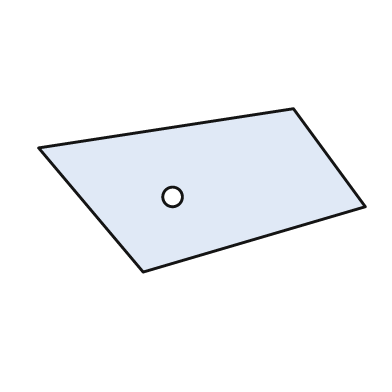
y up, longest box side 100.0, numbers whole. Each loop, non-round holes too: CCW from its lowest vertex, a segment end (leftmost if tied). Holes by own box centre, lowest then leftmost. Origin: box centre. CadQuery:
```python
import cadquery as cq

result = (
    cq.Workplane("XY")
    .moveTo(-18.0, -25.0)
    .lineTo(50.0, -5.0)
    .lineTo(28.0, 25.0)
    .lineTo(-50.0, 13.0)
    .close()
    .moveTo(-9.0, -2.0)
    .circle(3.0)
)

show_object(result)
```